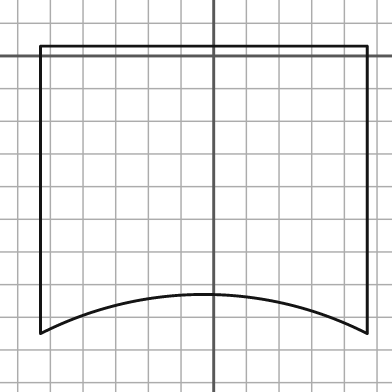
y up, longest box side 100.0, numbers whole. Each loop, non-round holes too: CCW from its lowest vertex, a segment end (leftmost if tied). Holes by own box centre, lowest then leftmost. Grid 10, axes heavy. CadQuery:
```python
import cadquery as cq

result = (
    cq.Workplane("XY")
    .moveTo(-53.0, -85.0)
    .threePointArc((-3.0, -73.0), (47.0, -85.0))
    .lineTo(47.0, 3.0)
    .lineTo(-53.0, 3.0)
    .close()
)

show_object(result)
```